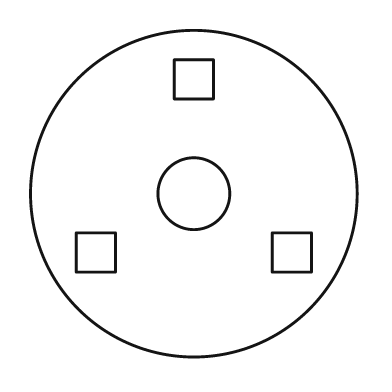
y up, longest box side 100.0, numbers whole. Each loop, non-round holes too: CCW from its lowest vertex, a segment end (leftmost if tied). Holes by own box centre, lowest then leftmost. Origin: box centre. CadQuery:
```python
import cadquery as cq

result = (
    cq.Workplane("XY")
    .moveTo(0.0, 0.0)
    .circle(50.0)
    .moveTo(-36.0, -24.0)
    .lineTo(-24.0, -24.0)
    .lineTo(-24.0, -12.0)
    .lineTo(-36.0, -12.0)
    .close()
    .moveTo(24.0, -24.0)
    .lineTo(36.0, -24.0)
    .lineTo(36.0, -12.0)
    .lineTo(24.0, -12.0)
    .close()
    .moveTo(0.0, 0.0)
    .circle(11.0)
    .moveTo(-6.0, 29.0)
    .lineTo(6.0, 29.0)
    .lineTo(6.0, 41.0)
    .lineTo(-6.0, 41.0)
    .close()
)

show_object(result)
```